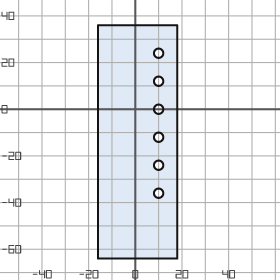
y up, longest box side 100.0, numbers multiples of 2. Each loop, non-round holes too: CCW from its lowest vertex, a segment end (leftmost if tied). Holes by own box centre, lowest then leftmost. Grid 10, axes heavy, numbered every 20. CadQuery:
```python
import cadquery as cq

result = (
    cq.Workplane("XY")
    .moveTo(-16.0, -64.0)
    .lineTo(18.0, -64.0)
    .lineTo(18.0, 36.0)
    .lineTo(-16.0, 36.0)
    .close()
    .moveTo(10.0, -36.0)
    .circle(2.0)
    .moveTo(10.0, -24.0)
    .circle(2.0)
    .moveTo(10.0, -12.0)
    .circle(2.0)
    .moveTo(10.0, 0.0)
    .circle(2.0)
    .moveTo(10.0, 12.0)
    .circle(2.0)
    .moveTo(10.0, 24.0)
    .circle(2.0)
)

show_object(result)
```